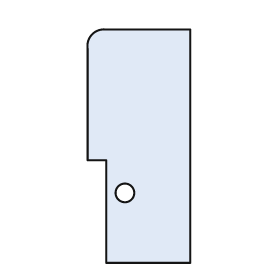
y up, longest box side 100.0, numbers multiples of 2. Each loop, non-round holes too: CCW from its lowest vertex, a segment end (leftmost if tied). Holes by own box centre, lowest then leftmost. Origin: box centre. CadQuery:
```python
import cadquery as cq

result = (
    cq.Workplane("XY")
    .moveTo(-14.0, -50.0)
    .lineTo(22.0, -50.0)
    .lineTo(22.0, 50.0)
    .lineTo(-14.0, 50.0)
    .threePointArc((-20.0, 48.0), (-22.0, 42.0))
    .lineTo(-22.0, -6.0)
    .lineTo(-14.0, -6.0)
    .close()
    .moveTo(-6.0, -20.0)
    .circle(4.0)
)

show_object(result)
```